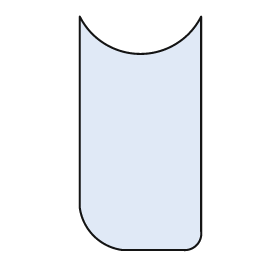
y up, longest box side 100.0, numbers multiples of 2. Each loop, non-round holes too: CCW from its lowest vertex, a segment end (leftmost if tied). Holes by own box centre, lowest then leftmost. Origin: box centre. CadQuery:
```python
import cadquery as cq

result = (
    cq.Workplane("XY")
    .moveTo(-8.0, -50.0)
    .lineTo(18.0, -50.0)
    .threePointArc((24.0, -48.0), (26.0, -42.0))
    .lineTo(26.0, 50.0)
    .threePointArc((0.0, 34.0), (-26.0, 50.0))
    .lineTo(-26.0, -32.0)
    .threePointArc((-20.0, -44.0), (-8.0, -50.0))
    .close()
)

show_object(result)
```